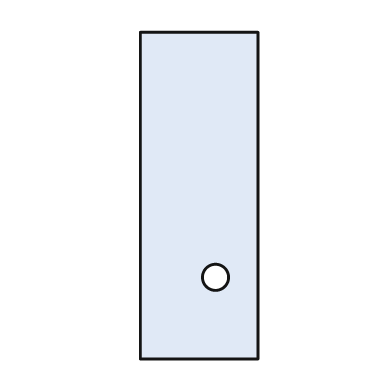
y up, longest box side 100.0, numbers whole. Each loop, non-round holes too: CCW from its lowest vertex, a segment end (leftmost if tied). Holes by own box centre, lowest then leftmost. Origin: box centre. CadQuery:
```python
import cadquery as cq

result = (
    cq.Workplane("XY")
    .moveTo(-18.0, -50.0)
    .lineTo(18.0, -50.0)
    .lineTo(18.0, 50.0)
    .lineTo(-18.0, 50.0)
    .close()
    .moveTo(5.0, -25.0)
    .circle(4.0)
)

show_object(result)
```